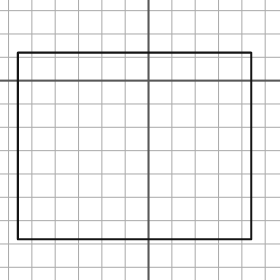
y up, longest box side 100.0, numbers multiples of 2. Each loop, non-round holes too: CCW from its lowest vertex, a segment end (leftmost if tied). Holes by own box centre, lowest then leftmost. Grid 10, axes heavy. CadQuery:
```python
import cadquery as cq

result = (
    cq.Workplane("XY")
    .moveTo(-56.0, -68.0)
    .lineTo(44.0, -68.0)
    .lineTo(44.0, 12.0)
    .lineTo(-56.0, 12.0)
    .close()
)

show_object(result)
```